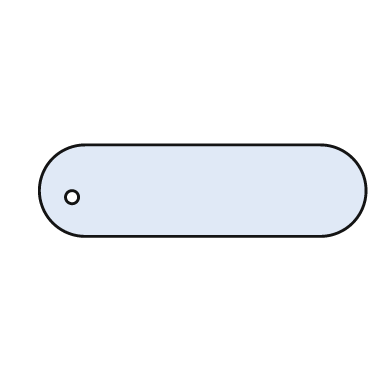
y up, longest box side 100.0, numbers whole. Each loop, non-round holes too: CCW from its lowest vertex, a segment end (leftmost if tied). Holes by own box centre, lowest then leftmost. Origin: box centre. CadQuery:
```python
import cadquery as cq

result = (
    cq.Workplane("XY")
    .moveTo(-36.0, -14.0)
    .lineTo(36.0, -14.0)
    .threePointArc((50.0, 0.0), (36.0, 14.0))
    .lineTo(-36.0, 14.0)
    .threePointArc((-50.0, 0.0), (-36.0, -14.0))
    .close()
    .moveTo(-40.0, -2.0)
    .circle(2.0)
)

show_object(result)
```